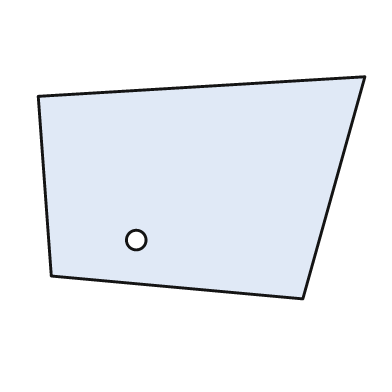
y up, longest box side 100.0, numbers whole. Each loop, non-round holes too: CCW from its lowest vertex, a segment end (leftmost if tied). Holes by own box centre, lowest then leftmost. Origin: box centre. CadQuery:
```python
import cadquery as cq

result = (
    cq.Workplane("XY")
    .moveTo(31.0, -34.0)
    .lineTo(50.0, 34.0)
    .lineTo(-50.0, 28.0)
    .lineTo(-46.0, -27.0)
    .close()
    .moveTo(-20.0, -16.0)
    .circle(3.0)
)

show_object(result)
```